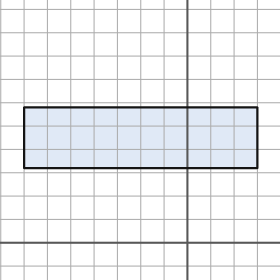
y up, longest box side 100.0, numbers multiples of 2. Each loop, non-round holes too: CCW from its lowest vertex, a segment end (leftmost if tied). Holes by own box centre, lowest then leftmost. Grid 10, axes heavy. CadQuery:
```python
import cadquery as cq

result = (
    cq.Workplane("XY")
    .moveTo(-70.0, 32.0)
    .lineTo(30.0, 32.0)
    .lineTo(30.0, 58.0)
    .lineTo(-70.0, 58.0)
    .close()
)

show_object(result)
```